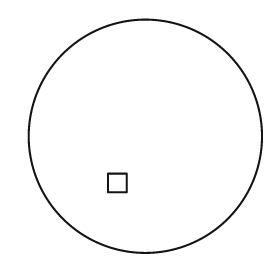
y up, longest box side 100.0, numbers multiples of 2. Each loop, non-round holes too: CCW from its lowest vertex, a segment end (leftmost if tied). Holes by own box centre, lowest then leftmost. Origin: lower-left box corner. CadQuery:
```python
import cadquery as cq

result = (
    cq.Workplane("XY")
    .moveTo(50.0, 50.0)
    .circle(50.0)
    .moveTo(34.0, 26.0)
    .lineTo(42.0, 26.0)
    .lineTo(42.0, 34.0)
    .lineTo(34.0, 34.0)
    .close()
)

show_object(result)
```